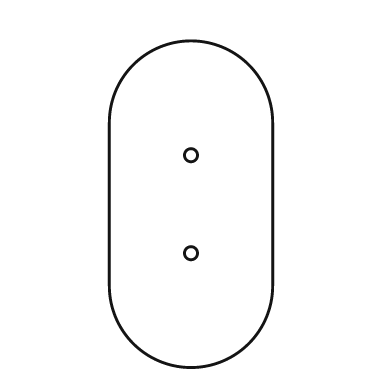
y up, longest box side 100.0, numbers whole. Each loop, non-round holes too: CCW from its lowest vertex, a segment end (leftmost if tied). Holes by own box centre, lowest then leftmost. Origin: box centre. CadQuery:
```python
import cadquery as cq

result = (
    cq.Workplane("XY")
    .moveTo(-25.0, -25.0)
    .threePointArc((0.0, -50.0), (25.0, -25.0))
    .lineTo(25.0, 25.0)
    .threePointArc((0.0, 50.0), (-25.0, 25.0))
    .close()
    .moveTo(0.0, -15.0)
    .circle(2.0)
    .moveTo(0.0, 15.0)
    .circle(2.0)
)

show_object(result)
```